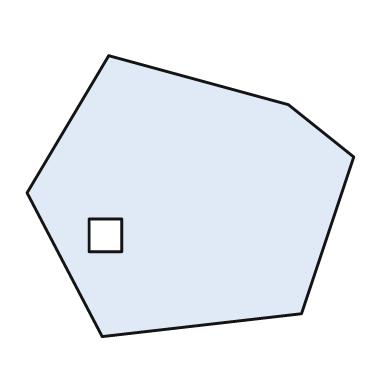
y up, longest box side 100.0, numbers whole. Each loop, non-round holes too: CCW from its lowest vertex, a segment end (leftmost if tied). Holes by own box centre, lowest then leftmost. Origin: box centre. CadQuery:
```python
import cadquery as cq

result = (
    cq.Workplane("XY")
    .moveTo(-27.0, -43.0)
    .lineTo(34.0, -36.0)
    .lineTo(50.0, 12.0)
    .lineTo(30.0, 28.0)
    .lineTo(-25.0, 43.0)
    .lineTo(-50.0, 1.0)
    .close()
    .moveTo(-31.0, -17.0)
    .lineTo(-21.0, -17.0)
    .lineTo(-21.0, -7.0)
    .lineTo(-31.0, -7.0)
    .close()
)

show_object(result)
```